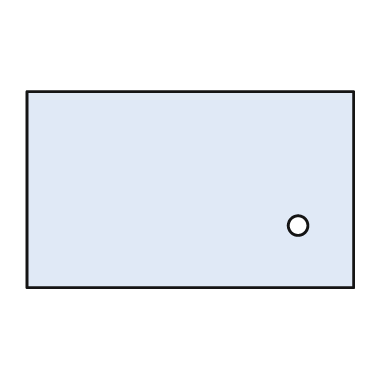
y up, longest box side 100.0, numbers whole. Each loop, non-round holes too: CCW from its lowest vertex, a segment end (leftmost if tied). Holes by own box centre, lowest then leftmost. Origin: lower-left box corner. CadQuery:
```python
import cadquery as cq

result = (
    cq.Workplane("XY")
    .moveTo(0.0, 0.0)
    .lineTo(100.0, 0.0)
    .lineTo(100.0, 60.0)
    .lineTo(0.0, 60.0)
    .close()
    .moveTo(83.0, 19.0)
    .circle(3.0)
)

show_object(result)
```